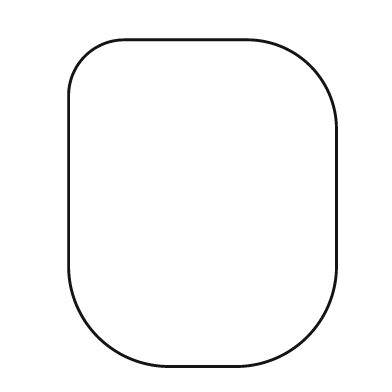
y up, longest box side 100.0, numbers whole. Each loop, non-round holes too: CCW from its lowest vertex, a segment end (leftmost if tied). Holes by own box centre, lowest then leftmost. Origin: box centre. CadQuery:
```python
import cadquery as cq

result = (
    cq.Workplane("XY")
    .moveTo(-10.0, -50.0)
    .lineTo(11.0, -50.0)
    .threePointArc((32.0, -41.0), (41.0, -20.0))
    .lineTo(41.0, 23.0)
    .threePointArc((33.0, 42.0), (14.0, 50.0))
    .lineTo(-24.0, 50.0)
    .threePointArc((-36.0, 45.0), (-41.0, 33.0))
    .lineTo(-41.0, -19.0)
    .threePointArc((-32.0, -41.0), (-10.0, -50.0))
    .close()
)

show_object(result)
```